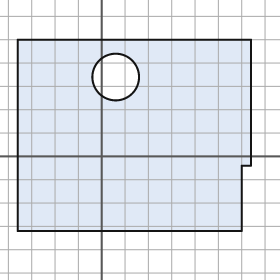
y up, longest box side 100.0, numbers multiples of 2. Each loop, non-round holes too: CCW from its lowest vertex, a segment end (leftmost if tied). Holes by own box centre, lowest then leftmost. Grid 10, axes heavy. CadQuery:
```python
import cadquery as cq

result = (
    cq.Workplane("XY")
    .moveTo(-36.0, -32.0)
    .lineTo(60.0, -32.0)
    .lineTo(60.0, -4.0)
    .lineTo(64.0, -4.0)
    .lineTo(64.0, 50.0)
    .lineTo(-36.0, 50.0)
    .close()
    .moveTo(6.0, 34.0)
    .circle(10.0)
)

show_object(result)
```